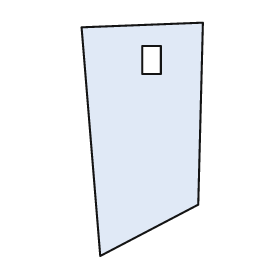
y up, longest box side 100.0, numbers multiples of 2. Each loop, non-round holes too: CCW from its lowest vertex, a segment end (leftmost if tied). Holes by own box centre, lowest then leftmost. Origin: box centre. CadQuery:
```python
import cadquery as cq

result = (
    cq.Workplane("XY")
    .moveTo(-18.0, -50.0)
    .lineTo(24.0, -28.0)
    .lineTo(26.0, 50.0)
    .lineTo(-26.0, 48.0)
    .close()
    .moveTo(0.0, 28.0)
    .lineTo(8.0, 28.0)
    .lineTo(8.0, 40.0)
    .lineTo(0.0, 40.0)
    .close()
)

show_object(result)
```